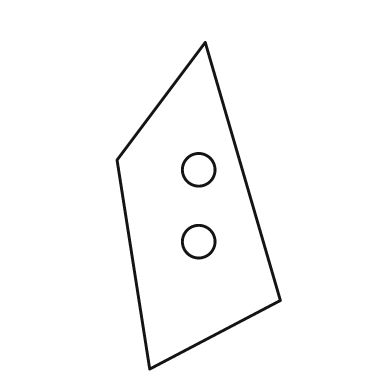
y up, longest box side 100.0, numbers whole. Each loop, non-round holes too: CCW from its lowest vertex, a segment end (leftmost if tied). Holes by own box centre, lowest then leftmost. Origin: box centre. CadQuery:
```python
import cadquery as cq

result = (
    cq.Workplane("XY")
    .moveTo(-15.0, -50.0)
    .lineTo(25.0, -29.0)
    .lineTo(2.0, 50.0)
    .lineTo(-25.0, 14.0)
    .close()
    .moveTo(0.0, -11.0)
    .circle(5.0)
    .moveTo(0.0, 11.0)
    .circle(5.0)
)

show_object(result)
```